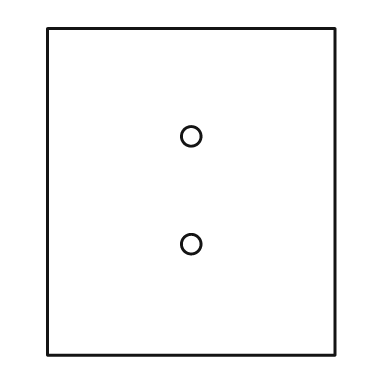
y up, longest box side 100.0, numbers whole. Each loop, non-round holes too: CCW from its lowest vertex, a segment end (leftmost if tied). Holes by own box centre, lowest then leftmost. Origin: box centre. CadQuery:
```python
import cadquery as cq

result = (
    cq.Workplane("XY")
    .moveTo(-44.0, -50.0)
    .lineTo(44.0, -50.0)
    .lineTo(44.0, 50.0)
    .lineTo(-44.0, 50.0)
    .close()
    .moveTo(0.0, -16.0)
    .circle(3.0)
    .moveTo(0.0, 17.0)
    .circle(3.0)
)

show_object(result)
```